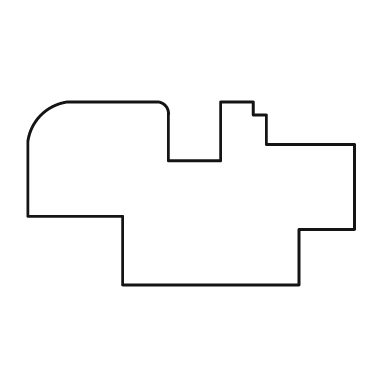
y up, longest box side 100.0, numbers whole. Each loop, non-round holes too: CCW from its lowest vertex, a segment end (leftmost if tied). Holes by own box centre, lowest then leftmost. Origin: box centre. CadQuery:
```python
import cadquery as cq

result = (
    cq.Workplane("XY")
    .moveTo(-21.0, -28.0)
    .lineTo(33.0, -28.0)
    .lineTo(33.0, -11.0)
    .lineTo(50.0, -11.0)
    .lineTo(50.0, 15.0)
    .lineTo(23.0, 15.0)
    .lineTo(23.0, 24.0)
    .lineTo(19.0, 24.0)
    .lineTo(19.0, 28.0)
    .lineTo(9.0, 28.0)
    .lineTo(9.0, 10.0)
    .lineTo(-7.0, 10.0)
    .lineTo(-7.0, 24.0)
    .threePointArc((-8.0, 27.0), (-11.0, 28.0))
    .lineTo(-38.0, 28.0)
    .threePointArc((-46.0, 24.0), (-50.0, 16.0))
    .lineTo(-50.0, -7.0)
    .lineTo(-21.0, -7.0)
    .close()
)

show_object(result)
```